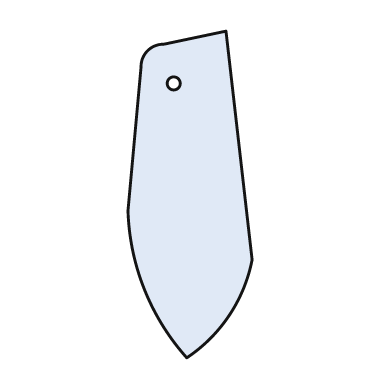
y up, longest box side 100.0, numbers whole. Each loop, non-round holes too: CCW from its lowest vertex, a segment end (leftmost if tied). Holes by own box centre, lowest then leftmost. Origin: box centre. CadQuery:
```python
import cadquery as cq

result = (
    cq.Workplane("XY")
    .moveTo(-1.0, -50.0)
    .threePointArc((12.0, -37.0), (19.0, -20.0))
    .lineTo(11.0, 50.0)
    .lineTo(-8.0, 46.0)
    .threePointArc((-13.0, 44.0), (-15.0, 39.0))
    .lineTo(-19.0, -5.0)
    .threePointArc((-14.0, -29.0), (-1.0, -50.0))
    .close()
    .moveTo(-5.0, 34.0)
    .circle(2.0)
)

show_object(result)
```